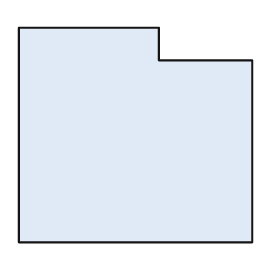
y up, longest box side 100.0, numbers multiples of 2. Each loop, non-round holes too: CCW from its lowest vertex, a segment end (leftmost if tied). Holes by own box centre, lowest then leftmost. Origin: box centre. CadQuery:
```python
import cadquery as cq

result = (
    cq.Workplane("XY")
    .moveTo(-50.0, -46.0)
    .lineTo(50.0, -46.0)
    .lineTo(50.0, 32.0)
    .lineTo(10.0, 32.0)
    .lineTo(10.0, 46.0)
    .lineTo(-50.0, 46.0)
    .close()
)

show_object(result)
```